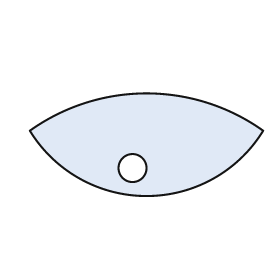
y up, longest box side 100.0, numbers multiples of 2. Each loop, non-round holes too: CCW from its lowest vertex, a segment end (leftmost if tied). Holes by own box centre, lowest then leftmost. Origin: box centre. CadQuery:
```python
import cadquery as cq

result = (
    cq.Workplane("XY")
    .moveTo(-50.0, 6.0)
    .threePointArc((0.0, -22.0), (50.0, 6.0))
    .threePointArc((0.0, 22.0), (-50.0, 6.0))
    .close()
    .moveTo(-6.0, -10.0)
    .circle(6.0)
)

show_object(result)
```